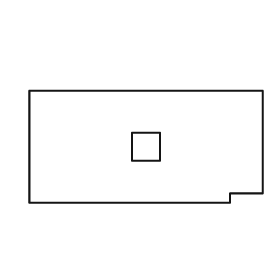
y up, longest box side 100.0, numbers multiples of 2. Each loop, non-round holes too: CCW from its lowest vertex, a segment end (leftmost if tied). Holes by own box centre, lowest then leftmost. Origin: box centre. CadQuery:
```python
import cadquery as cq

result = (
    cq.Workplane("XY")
    .moveTo(-50.0, -24.0)
    .lineTo(36.0, -24.0)
    .lineTo(36.0, -20.0)
    .lineTo(50.0, -20.0)
    .lineTo(50.0, 24.0)
    .lineTo(-50.0, 24.0)
    .close()
    .moveTo(-6.0, -6.0)
    .lineTo(6.0, -6.0)
    .lineTo(6.0, 6.0)
    .lineTo(-6.0, 6.0)
    .close()
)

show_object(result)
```